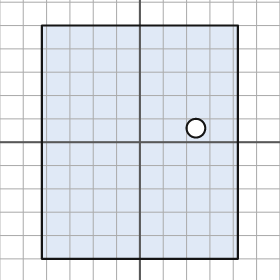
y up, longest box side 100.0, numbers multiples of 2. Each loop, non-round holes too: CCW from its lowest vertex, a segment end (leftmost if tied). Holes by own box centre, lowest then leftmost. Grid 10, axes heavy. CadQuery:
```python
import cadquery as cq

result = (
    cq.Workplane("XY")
    .moveTo(-42.0, -50.0)
    .lineTo(42.0, -50.0)
    .lineTo(42.0, 50.0)
    .lineTo(-42.0, 50.0)
    .close()
    .moveTo(24.0, 6.0)
    .circle(4.0)
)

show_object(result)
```